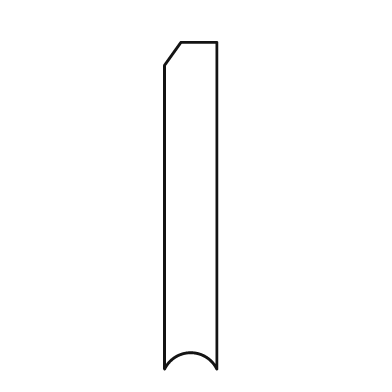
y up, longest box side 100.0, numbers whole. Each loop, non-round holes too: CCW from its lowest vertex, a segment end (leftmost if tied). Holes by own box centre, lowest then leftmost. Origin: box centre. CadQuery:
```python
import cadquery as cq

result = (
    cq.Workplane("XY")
    .moveTo(-8.0, -50.0)
    .threePointArc((0.0, -45.0), (8.0, -50.0))
    .lineTo(8.0, 50.0)
    .lineTo(-3.0, 50.0)
    .lineTo(-8.0, 43.0)
    .close()
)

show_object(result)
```